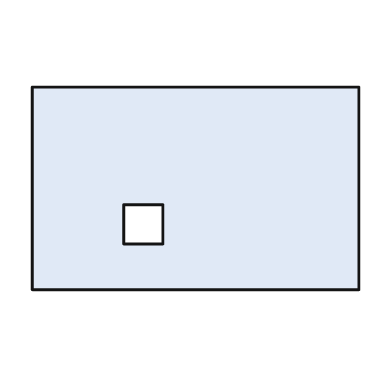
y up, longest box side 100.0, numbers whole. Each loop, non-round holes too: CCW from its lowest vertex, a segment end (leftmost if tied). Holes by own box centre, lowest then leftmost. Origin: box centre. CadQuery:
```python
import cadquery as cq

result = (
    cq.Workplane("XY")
    .moveTo(-50.0, -31.0)
    .lineTo(50.0, -31.0)
    .lineTo(50.0, 31.0)
    .lineTo(-50.0, 31.0)
    .close()
    .moveTo(-22.0, -17.0)
    .lineTo(-10.0, -17.0)
    .lineTo(-10.0, -5.0)
    .lineTo(-22.0, -5.0)
    .close()
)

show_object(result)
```